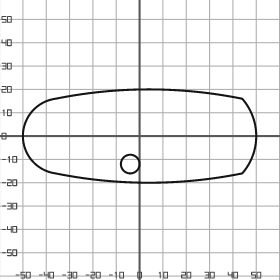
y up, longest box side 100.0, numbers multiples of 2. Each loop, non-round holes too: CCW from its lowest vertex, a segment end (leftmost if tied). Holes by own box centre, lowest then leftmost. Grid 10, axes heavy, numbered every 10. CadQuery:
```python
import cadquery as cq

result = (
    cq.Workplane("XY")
    .moveTo(-36.0, -16.0)
    .threePointArc((4.0, -20.0), (44.0, -16.0))
    .threePointArc((50.0, 0.0), (44.0, 16.0))
    .threePointArc((4.0, 20.0), (-36.0, 16.0))
    .threePointArc((-50.0, 0.0), (-36.0, -16.0))
    .close()
    .moveTo(-4.0, -12.0)
    .circle(4.0)
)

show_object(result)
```